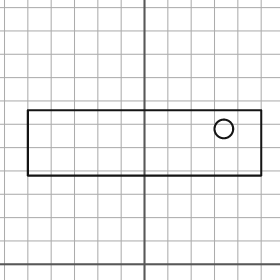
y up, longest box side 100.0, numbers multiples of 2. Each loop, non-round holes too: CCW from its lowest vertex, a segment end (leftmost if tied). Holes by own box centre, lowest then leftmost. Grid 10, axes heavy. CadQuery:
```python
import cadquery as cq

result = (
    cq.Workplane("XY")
    .moveTo(-50.0, 38.0)
    .lineTo(50.0, 38.0)
    .lineTo(50.0, 66.0)
    .lineTo(-50.0, 66.0)
    .close()
    .moveTo(34.0, 58.0)
    .circle(4.0)
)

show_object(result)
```